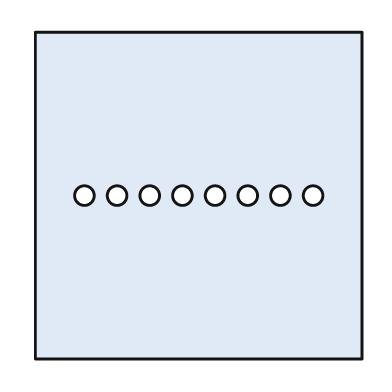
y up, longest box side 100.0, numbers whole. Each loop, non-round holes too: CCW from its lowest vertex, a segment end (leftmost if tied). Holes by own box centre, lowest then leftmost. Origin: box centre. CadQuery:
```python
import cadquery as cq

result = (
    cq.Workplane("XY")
    .moveTo(-50.0, -50.0)
    .lineTo(50.0, -50.0)
    .lineTo(50.0, 50.0)
    .lineTo(-50.0, 50.0)
    .close()
    .moveTo(-35.0, 0.0)
    .circle(3.0)
    .moveTo(-25.0, 0.0)
    .circle(3.0)
    .moveTo(-15.0, 0.0)
    .circle(3.0)
    .moveTo(-5.0, 0.0)
    .circle(3.0)
    .moveTo(5.0, 0.0)
    .circle(3.0)
    .moveTo(15.0, 0.0)
    .circle(3.0)
    .moveTo(25.0, 0.0)
    .circle(3.0)
    .moveTo(35.0, 0.0)
    .circle(3.0)
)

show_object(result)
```